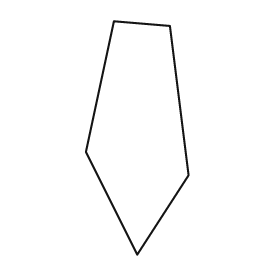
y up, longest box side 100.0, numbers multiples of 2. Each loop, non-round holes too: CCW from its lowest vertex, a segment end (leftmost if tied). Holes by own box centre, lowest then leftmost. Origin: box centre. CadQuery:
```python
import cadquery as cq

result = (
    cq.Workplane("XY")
    .moveTo(0.0, -50.0)
    .lineTo(22.0, -16.0)
    .lineTo(14.0, 48.0)
    .lineTo(-10.0, 50.0)
    .lineTo(-22.0, -6.0)
    .close()
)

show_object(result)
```